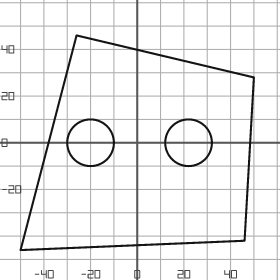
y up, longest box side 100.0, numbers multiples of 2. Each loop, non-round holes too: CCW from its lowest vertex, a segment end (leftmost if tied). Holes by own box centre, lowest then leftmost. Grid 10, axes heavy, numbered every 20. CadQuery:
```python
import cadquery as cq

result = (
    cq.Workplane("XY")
    .moveTo(-50.0, -46.0)
    .lineTo(46.0, -42.0)
    .lineTo(50.0, 28.0)
    .lineTo(-26.0, 46.0)
    .close()
    .moveTo(-20.0, 0.0)
    .circle(10.0)
    .moveTo(22.0, 0.0)
    .circle(10.0)
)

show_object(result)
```